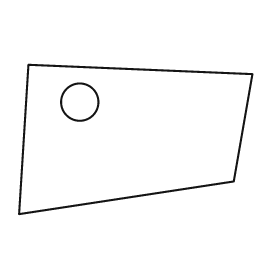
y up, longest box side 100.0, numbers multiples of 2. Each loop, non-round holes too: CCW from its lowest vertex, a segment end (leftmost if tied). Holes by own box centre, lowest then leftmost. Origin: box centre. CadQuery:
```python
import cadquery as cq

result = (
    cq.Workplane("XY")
    .moveTo(-50.0, -32.0)
    .lineTo(42.0, -18.0)
    .lineTo(50.0, 28.0)
    .lineTo(-46.0, 32.0)
    .close()
    .moveTo(-24.0, 16.0)
    .circle(8.0)
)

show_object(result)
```